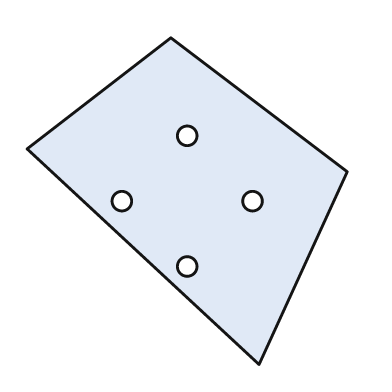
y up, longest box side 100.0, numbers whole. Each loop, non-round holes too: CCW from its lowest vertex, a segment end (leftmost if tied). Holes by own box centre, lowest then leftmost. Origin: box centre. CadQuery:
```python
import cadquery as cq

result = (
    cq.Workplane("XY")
    .moveTo(22.0, -50.0)
    .lineTo(49.0, 9.0)
    .lineTo(-5.0, 50.0)
    .lineTo(-49.0, 16.0)
    .close()
    .moveTo(0.0, -20.0)
    .circle(3.0)
    .moveTo(-20.0, 0.0)
    .circle(3.0)
    .moveTo(20.0, 0.0)
    .circle(3.0)
    .moveTo(0.0, 20.0)
    .circle(3.0)
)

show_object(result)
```